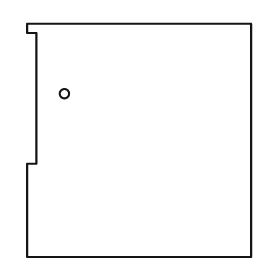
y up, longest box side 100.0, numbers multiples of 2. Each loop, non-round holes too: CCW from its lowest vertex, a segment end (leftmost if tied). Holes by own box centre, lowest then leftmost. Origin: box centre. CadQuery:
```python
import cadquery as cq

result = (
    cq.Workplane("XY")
    .moveTo(-48.0, -50.0)
    .lineTo(48.0, -50.0)
    .lineTo(48.0, 50.0)
    .lineTo(-48.0, 50.0)
    .lineTo(-48.0, 46.0)
    .lineTo(-44.0, 46.0)
    .lineTo(-44.0, -10.0)
    .lineTo(-48.0, -10.0)
    .close()
    .moveTo(-32.0, 20.0)
    .circle(2.0)
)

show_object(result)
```